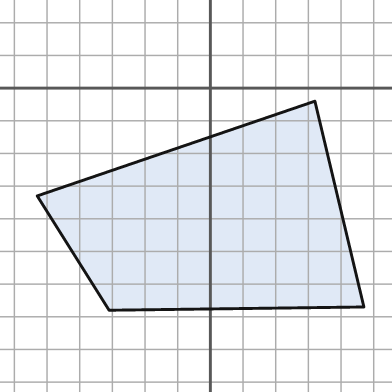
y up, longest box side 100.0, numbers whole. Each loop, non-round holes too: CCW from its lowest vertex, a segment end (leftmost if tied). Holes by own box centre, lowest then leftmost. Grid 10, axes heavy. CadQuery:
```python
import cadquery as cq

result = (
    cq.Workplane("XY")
    .moveTo(-31.0, -68.0)
    .lineTo(47.0, -67.0)
    .lineTo(32.0, -4.0)
    .lineTo(-53.0, -33.0)
    .close()
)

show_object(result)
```